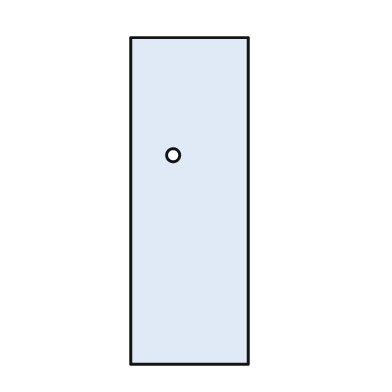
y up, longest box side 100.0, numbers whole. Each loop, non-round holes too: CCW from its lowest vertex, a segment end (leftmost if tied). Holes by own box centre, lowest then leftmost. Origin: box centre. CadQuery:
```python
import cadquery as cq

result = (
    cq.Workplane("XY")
    .moveTo(-18.0, -50.0)
    .lineTo(18.0, -50.0)
    .lineTo(18.0, 50.0)
    .lineTo(-18.0, 50.0)
    .close()
    .moveTo(-5.0, 14.0)
    .circle(2.0)
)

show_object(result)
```